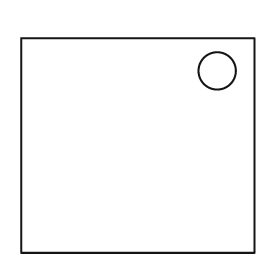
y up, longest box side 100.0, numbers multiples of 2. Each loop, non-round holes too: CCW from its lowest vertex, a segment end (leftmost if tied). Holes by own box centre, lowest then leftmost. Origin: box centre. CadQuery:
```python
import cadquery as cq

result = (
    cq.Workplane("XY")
    .moveTo(-50.0, -46.0)
    .lineTo(50.0, -46.0)
    .lineTo(50.0, 46.0)
    .lineTo(-50.0, 46.0)
    .close()
    .moveTo(34.0, 32.0)
    .circle(8.0)
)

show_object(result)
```